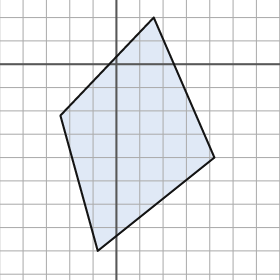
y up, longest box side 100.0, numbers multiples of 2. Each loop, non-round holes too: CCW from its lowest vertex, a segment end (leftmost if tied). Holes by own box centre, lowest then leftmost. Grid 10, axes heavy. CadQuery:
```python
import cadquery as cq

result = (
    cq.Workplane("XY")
    .moveTo(-8.0, -80.0)
    .lineTo(42.0, -40.0)
    .lineTo(16.0, 20.0)
    .lineTo(-24.0, -22.0)
    .close()
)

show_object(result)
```